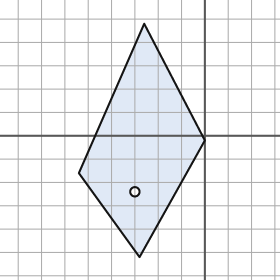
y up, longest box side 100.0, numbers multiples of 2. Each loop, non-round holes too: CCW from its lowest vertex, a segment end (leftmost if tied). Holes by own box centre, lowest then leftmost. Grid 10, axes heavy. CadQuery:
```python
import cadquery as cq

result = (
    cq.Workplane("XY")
    .moveTo(-28.0, -52.0)
    .lineTo(0.0, -2.0)
    .lineTo(-26.0, 48.0)
    .lineTo(-54.0, -16.0)
    .close()
    .moveTo(-30.0, -24.0)
    .circle(2.0)
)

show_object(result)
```